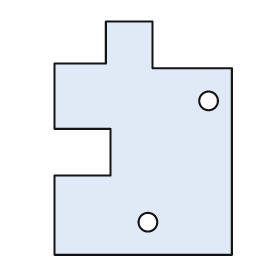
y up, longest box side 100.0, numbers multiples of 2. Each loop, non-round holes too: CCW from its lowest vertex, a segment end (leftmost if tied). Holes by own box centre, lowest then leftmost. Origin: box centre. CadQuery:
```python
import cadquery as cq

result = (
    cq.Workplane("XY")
    .moveTo(-38.0, -50.0)
    .lineTo(38.0, -50.0)
    .lineTo(38.0, 30.0)
    .lineTo(4.0, 30.0)
    .lineTo(4.0, 50.0)
    .lineTo(-16.0, 50.0)
    .lineTo(-16.0, 32.0)
    .lineTo(-38.0, 32.0)
    .lineTo(-38.0, 4.0)
    .lineTo(-14.0, 4.0)
    .lineTo(-14.0, -16.0)
    .lineTo(-38.0, -16.0)
    .close()
    .moveTo(2.0, -36.0)
    .circle(4.0)
    .moveTo(28.0, 16.0)
    .circle(4.0)
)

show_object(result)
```